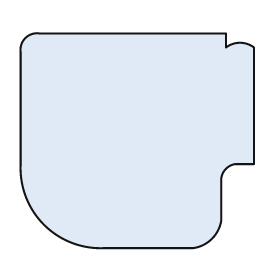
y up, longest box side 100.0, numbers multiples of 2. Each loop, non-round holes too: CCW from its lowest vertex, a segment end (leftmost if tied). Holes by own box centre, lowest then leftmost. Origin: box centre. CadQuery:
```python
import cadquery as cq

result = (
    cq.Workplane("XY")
    .moveTo(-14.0, -46.0)
    .lineTo(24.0, -46.0)
    .threePointArc((32.0, -42.0), (36.0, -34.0))
    .lineTo(36.0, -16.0)
    .threePointArc((38.0, -12.0), (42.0, -10.0))
    .lineTo(50.0, -10.0)
    .lineTo(50.0, 40.0)
    .threePointArc((44.0, 42.0), (38.0, 40.0))
    .lineTo(38.0, 46.0)
    .lineTo(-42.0, 46.0)
    .threePointArc((-48.0, 44.0), (-50.0, 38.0))
    .lineTo(-50.0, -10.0)
    .threePointArc((-40.0, -36.0), (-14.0, -46.0))
    .close()
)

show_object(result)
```